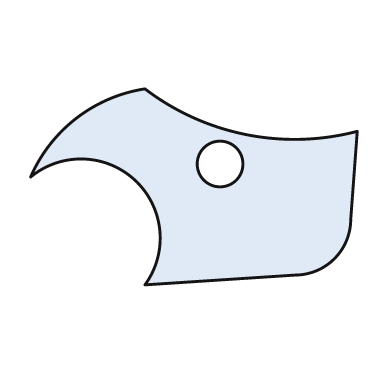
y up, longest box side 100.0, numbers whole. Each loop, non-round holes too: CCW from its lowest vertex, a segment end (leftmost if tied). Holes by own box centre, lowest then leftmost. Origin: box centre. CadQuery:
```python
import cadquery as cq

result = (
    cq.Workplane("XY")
    .moveTo(-15.0, -30.0)
    .lineTo(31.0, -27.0)
    .threePointArc((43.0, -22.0), (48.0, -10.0))
    .lineTo(50.0, 17.0)
    .threePointArc((16.0, 16.0), (-15.0, 30.0))
    .threePointArc((-36.0, 21.0), (-50.0, 3.0))
    .threePointArc((-18.0, 2.0), (-15.0, -30.0))
    .close()
    .moveTo(8.0, 7.0)
    .circle(7.0)
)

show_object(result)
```